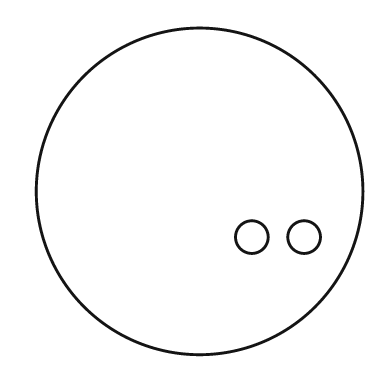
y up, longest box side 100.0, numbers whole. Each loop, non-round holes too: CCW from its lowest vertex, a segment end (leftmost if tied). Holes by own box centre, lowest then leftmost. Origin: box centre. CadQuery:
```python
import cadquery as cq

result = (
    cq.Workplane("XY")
    .moveTo(0.0, 0.0)
    .circle(50.0)
    .moveTo(16.0, -14.0)
    .circle(5.0)
    .moveTo(32.0, -14.0)
    .circle(5.0)
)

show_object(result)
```